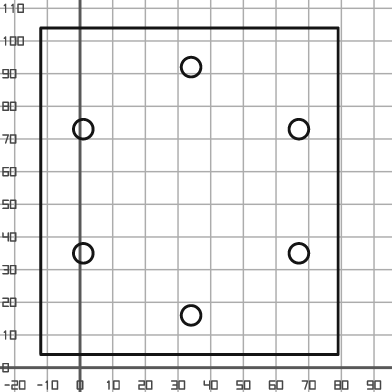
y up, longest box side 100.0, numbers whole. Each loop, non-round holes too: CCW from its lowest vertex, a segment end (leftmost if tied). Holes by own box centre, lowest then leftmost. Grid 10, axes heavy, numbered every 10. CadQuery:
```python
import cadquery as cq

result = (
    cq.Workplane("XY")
    .moveTo(-12.0, 4.0)
    .lineTo(79.0, 4.0)
    .lineTo(79.0, 104.0)
    .lineTo(-12.0, 104.0)
    .close()
    .moveTo(34.0, 16.0)
    .circle(3.0)
    .moveTo(1.0, 35.0)
    .circle(3.0)
    .moveTo(67.0, 35.0)
    .circle(3.0)
    .moveTo(1.0, 73.0)
    .circle(3.0)
    .moveTo(67.0, 73.0)
    .circle(3.0)
    .moveTo(34.0, 92.0)
    .circle(3.0)
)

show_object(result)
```